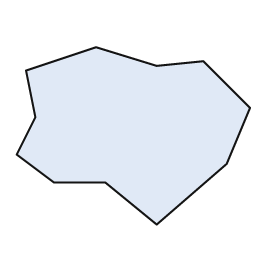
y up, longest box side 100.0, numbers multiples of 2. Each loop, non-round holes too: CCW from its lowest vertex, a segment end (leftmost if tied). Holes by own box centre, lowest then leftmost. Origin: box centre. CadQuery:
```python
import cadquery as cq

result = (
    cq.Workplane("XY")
    .moveTo(10.0, -38.0)
    .lineTo(40.0, -12.0)
    .lineTo(50.0, 12.0)
    .lineTo(30.0, 32.0)
    .lineTo(10.0, 30.0)
    .lineTo(-16.0, 38.0)
    .lineTo(-46.0, 28.0)
    .lineTo(-42.0, 8.0)
    .lineTo(-50.0, -8.0)
    .lineTo(-34.0, -20.0)
    .lineTo(-12.0, -20.0)
    .close()
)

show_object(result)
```